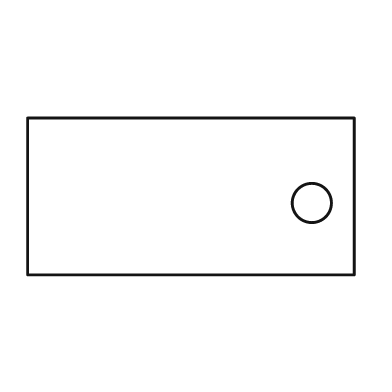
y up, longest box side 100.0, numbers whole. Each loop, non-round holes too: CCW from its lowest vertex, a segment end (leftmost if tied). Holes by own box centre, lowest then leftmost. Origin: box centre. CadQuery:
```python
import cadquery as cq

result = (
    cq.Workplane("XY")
    .moveTo(-50.0, -24.0)
    .lineTo(50.0, -24.0)
    .lineTo(50.0, 24.0)
    .lineTo(-50.0, 24.0)
    .close()
    .moveTo(37.0, -2.0)
    .circle(6.0)
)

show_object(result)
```